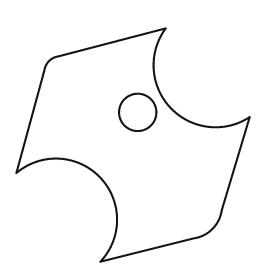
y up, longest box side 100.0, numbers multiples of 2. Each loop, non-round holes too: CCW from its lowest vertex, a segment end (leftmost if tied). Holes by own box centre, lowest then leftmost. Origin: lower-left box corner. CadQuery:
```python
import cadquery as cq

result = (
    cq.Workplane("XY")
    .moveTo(36.0, 0.0)
    .lineTo(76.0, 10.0)
    .threePointArc((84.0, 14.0), (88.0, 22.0))
    .lineTo(100.0, 62.0)
    .threePointArc((66.0, 66.0), (64.0, 100.0))
    .lineTo(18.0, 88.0)
    .threePointArc((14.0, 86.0), (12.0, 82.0))
    .lineTo(0.0, 38.0)
    .threePointArc((36.0, 36.0), (36.0, 0.0))
    .close()
    .moveTo(52.0, 64.0)
    .circle(8.0)
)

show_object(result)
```